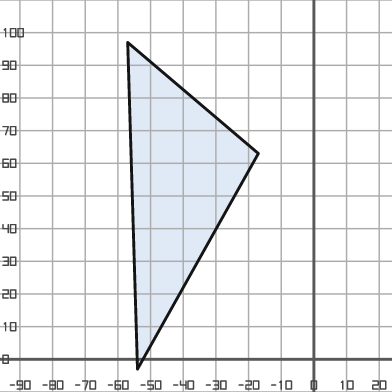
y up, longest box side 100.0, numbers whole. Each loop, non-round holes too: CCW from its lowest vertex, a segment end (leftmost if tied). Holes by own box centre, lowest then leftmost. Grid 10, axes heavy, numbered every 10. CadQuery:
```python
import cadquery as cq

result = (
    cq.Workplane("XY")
    .moveTo(-54.0, -3.0)
    .lineTo(-17.0, 63.0)
    .lineTo(-57.0, 97.0)
    .close()
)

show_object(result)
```